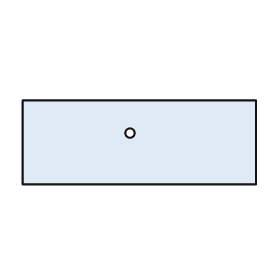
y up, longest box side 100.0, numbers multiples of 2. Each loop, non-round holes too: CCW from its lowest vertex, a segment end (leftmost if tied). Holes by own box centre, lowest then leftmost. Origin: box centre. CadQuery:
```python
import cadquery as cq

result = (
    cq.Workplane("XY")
    .moveTo(-50.0, -18.0)
    .lineTo(50.0, -18.0)
    .lineTo(50.0, 18.0)
    .lineTo(-50.0, 18.0)
    .close()
    .moveTo(-4.0, 4.0)
    .circle(2.0)
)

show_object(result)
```